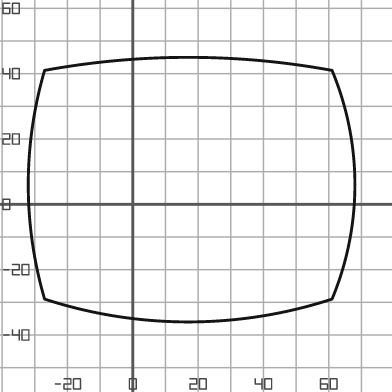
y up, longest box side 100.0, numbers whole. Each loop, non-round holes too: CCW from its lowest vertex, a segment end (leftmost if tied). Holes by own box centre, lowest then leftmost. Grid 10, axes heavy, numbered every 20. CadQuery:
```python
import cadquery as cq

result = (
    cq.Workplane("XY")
    .moveTo(-27.0, -29.0)
    .threePointArc((17.0, -36.0), (61.0, -29.0))
    .threePointArc((68.0, 6.0), (61.0, 41.0))
    .threePointArc((17.0, 45.0), (-27.0, 41.0))
    .threePointArc((-32.0, 6.0), (-27.0, -29.0))
    .close()
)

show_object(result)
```